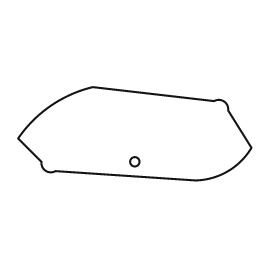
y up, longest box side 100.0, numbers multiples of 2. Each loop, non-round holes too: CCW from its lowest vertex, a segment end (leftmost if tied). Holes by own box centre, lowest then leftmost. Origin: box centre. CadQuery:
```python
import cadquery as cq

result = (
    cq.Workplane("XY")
    .moveTo(26.0, -20.0)
    .threePointArc((40.0, -16.0), (50.0, -6.0))
    .lineTo(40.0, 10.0)
    .threePointArc((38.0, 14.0), (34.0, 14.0))
    .lineTo(-18.0, 20.0)
    .threePointArc((-36.0, 12.0), (-50.0, -2.0))
    .lineTo(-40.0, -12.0)
    .threePointArc((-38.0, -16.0), (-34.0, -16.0))
    .close()
    .moveTo(0.0, -12.0)
    .circle(2.0)
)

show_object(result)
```